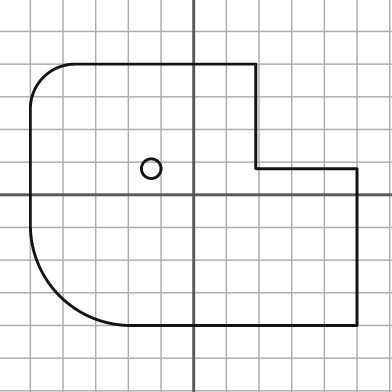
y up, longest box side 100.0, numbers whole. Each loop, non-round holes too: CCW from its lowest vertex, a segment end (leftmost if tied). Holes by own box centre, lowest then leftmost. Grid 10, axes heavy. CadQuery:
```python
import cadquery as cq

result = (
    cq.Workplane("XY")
    .moveTo(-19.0, -40.0)
    .lineTo(50.0, -40.0)
    .lineTo(50.0, 8.0)
    .lineTo(19.0, 8.0)
    .lineTo(19.0, 40.0)
    .lineTo(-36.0, 40.0)
    .threePointArc((-46.0, 36.0), (-50.0, 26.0))
    .lineTo(-50.0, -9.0)
    .threePointArc((-41.0, -31.0), (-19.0, -40.0))
    .close()
    .moveTo(-13.0, 8.0)
    .circle(3.0)
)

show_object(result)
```